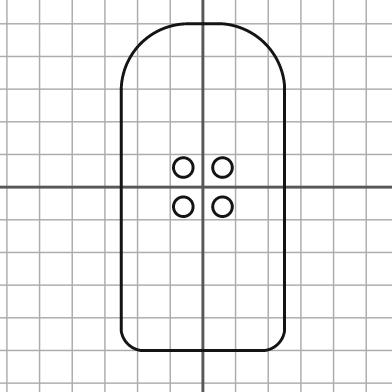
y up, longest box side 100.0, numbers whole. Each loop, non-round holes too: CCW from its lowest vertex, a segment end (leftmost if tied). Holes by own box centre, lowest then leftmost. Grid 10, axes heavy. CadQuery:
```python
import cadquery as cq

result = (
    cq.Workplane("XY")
    .moveTo(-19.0, -50.0)
    .lineTo(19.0, -50.0)
    .threePointArc((23.0, -48.0), (25.0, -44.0))
    .lineTo(25.0, 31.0)
    .threePointArc((19.0, 44.0), (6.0, 50.0))
    .lineTo(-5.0, 50.0)
    .threePointArc((-19.0, 44.0), (-25.0, 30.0))
    .lineTo(-25.0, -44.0)
    .threePointArc((-23.0, -48.0), (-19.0, -50.0))
    .close()
    .moveTo(-6.0, -6.0)
    .circle(3.0)
    .moveTo(6.0, -6.0)
    .circle(3.0)
    .moveTo(-6.0, 6.0)
    .circle(3.0)
    .moveTo(6.0, 6.0)
    .circle(3.0)
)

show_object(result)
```